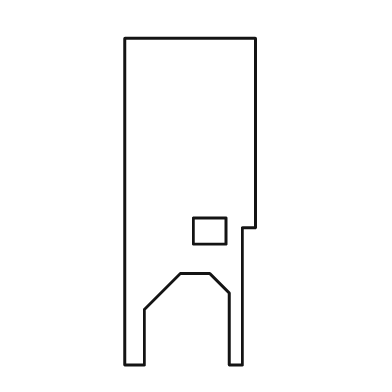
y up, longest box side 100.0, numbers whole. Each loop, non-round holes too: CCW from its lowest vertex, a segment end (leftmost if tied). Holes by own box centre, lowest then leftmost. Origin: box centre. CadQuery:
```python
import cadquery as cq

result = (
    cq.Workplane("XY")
    .moveTo(-20.0, -50.0)
    .lineTo(-14.0, -50.0)
    .lineTo(-14.0, -33.0)
    .lineTo(-3.0, -22.0)
    .lineTo(6.0, -22.0)
    .lineTo(12.0, -28.0)
    .lineTo(12.0, -50.0)
    .lineTo(16.0, -50.0)
    .lineTo(16.0, -8.0)
    .lineTo(20.0, -8.0)
    .lineTo(20.0, 50.0)
    .lineTo(-20.0, 50.0)
    .close()
    .moveTo(1.0, -13.0)
    .lineTo(11.0, -13.0)
    .lineTo(11.0, -5.0)
    .lineTo(1.0, -5.0)
    .close()
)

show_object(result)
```